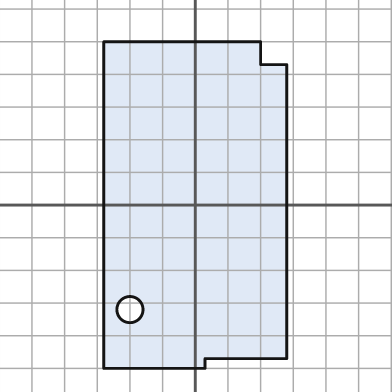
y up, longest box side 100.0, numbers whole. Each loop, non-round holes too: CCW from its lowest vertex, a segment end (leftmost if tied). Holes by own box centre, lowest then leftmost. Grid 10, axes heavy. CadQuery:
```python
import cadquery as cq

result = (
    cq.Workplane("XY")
    .moveTo(-28.0, -50.0)
    .lineTo(3.0, -50.0)
    .lineTo(3.0, -47.0)
    .lineTo(28.0, -47.0)
    .lineTo(28.0, 43.0)
    .lineTo(20.0, 43.0)
    .lineTo(20.0, 50.0)
    .lineTo(-28.0, 50.0)
    .close()
    .moveTo(-20.0, -32.0)
    .circle(4.0)
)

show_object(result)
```